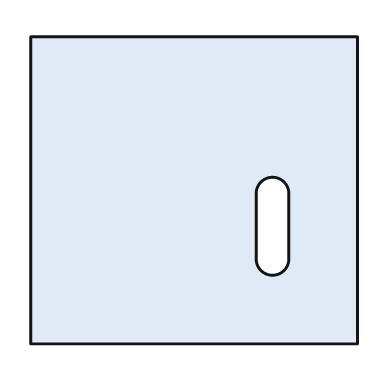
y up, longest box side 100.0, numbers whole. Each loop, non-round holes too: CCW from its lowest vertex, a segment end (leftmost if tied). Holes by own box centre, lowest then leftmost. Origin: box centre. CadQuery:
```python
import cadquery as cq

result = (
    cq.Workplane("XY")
    .moveTo(-50.0, -47.0)
    .lineTo(50.0, -47.0)
    .lineTo(50.0, 47.0)
    .lineTo(-50.0, 47.0)
    .close()
    .moveTo(19.0, -21.0)
    .threePointArc((24.0, -26.0), (29.0, -21.0))
    .lineTo(29.0, -1.0)
    .threePointArc((24.0, 4.0), (19.0, -1.0))
    .close()
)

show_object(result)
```